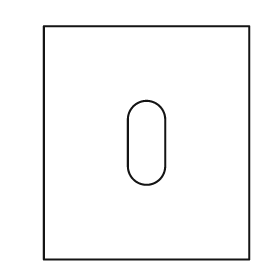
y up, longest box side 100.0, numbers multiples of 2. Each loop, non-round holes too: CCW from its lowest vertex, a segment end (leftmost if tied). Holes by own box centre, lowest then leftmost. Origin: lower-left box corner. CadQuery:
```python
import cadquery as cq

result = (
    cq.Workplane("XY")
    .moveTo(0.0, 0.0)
    .lineTo(88.0, 0.0)
    .lineTo(88.0, 100.0)
    .lineTo(0.0, 100.0)
    .close()
    .moveTo(36.0, 40.0)
    .threePointArc((44.0, 32.0), (52.0, 40.0))
    .lineTo(52.0, 60.0)
    .threePointArc((44.0, 68.0), (36.0, 60.0))
    .close()
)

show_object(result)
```